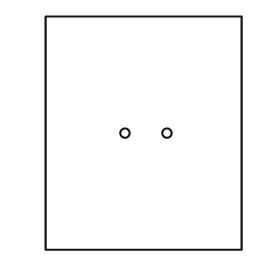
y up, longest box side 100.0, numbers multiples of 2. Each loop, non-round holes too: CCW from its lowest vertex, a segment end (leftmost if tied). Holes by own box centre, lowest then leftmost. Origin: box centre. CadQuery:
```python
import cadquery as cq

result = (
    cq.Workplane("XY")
    .moveTo(-42.0, -50.0)
    .lineTo(42.0, -50.0)
    .lineTo(42.0, 50.0)
    .lineTo(-42.0, 50.0)
    .close()
    .moveTo(-8.0, 0.0)
    .circle(2.0)
    .moveTo(10.0, 0.0)
    .circle(2.0)
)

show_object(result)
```